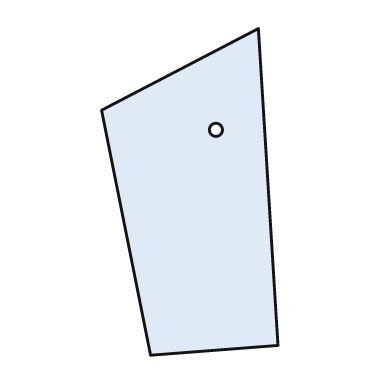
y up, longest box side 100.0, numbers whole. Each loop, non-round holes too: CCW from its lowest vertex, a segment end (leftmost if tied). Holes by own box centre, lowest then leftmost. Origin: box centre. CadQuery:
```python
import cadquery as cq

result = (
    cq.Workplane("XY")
    .moveTo(-12.0, -50.0)
    .lineTo(27.0, -47.0)
    .lineTo(21.0, 50.0)
    .lineTo(-27.0, 25.0)
    .close()
    .moveTo(8.0, 19.0)
    .circle(2.0)
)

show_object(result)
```